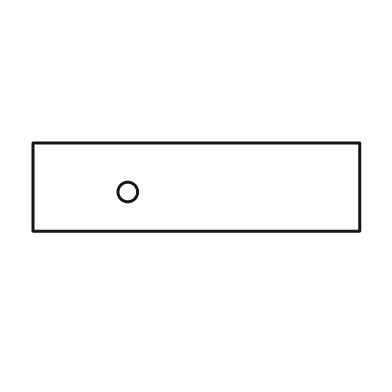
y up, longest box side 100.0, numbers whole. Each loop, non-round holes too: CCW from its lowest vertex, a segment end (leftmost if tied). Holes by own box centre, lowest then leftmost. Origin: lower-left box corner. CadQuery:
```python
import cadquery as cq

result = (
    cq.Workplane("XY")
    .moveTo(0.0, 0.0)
    .lineTo(100.0, 0.0)
    .lineTo(100.0, 27.0)
    .lineTo(0.0, 27.0)
    .close()
    .moveTo(29.0, 12.0)
    .circle(3.0)
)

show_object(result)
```